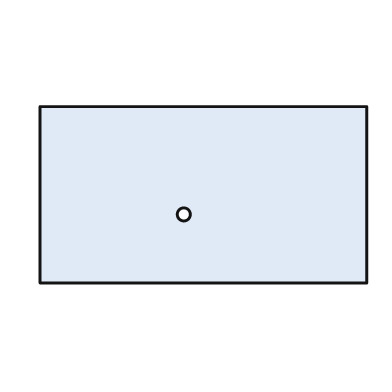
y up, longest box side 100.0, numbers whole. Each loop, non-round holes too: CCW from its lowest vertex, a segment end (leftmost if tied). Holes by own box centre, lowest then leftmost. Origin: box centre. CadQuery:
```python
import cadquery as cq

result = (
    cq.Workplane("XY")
    .moveTo(-50.0, -27.0)
    .lineTo(50.0, -27.0)
    .lineTo(50.0, 27.0)
    .lineTo(-50.0, 27.0)
    .close()
    .moveTo(-6.0, -6.0)
    .circle(2.0)
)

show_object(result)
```